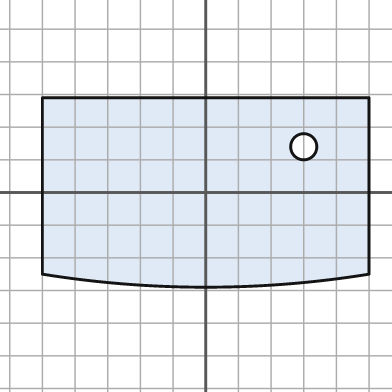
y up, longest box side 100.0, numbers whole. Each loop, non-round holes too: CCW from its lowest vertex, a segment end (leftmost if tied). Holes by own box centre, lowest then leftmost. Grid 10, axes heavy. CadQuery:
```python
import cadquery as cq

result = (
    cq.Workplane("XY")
    .moveTo(-50.0, -25.0)
    .threePointArc((0.0, -29.0), (50.0, -25.0))
    .lineTo(50.0, 29.0)
    .lineTo(-50.0, 29.0)
    .close()
    .moveTo(30.0, 14.0)
    .circle(4.0)
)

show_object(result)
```